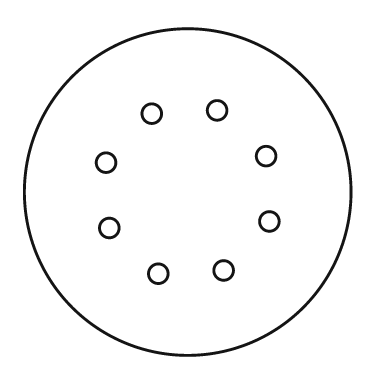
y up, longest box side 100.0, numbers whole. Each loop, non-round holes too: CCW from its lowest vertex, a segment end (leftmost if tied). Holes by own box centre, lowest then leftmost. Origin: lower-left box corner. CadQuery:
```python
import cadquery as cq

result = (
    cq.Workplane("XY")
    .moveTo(50.0, 50.0)
    .circle(50.0)
    .moveTo(41.0, 25.0)
    .circle(3.0)
    .moveTo(61.0, 26.0)
    .circle(3.0)
    .moveTo(26.0, 39.0)
    .circle(3.0)
    .moveTo(75.0, 41.0)
    .circle(3.0)
    .moveTo(25.0, 59.0)
    .circle(3.0)
    .moveTo(74.0, 61.0)
    .circle(3.0)
    .moveTo(39.0, 74.0)
    .circle(3.0)
    .moveTo(59.0, 75.0)
    .circle(3.0)
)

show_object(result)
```